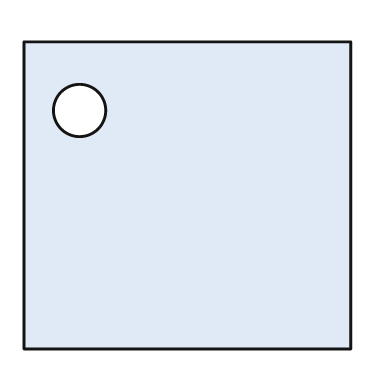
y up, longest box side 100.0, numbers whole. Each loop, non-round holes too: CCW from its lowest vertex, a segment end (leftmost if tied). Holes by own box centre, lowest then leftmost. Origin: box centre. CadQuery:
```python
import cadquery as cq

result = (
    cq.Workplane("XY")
    .moveTo(-50.0, -47.0)
    .lineTo(50.0, -47.0)
    .lineTo(50.0, 47.0)
    .lineTo(-50.0, 47.0)
    .close()
    .moveTo(-33.0, 26.0)
    .circle(8.0)
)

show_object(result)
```